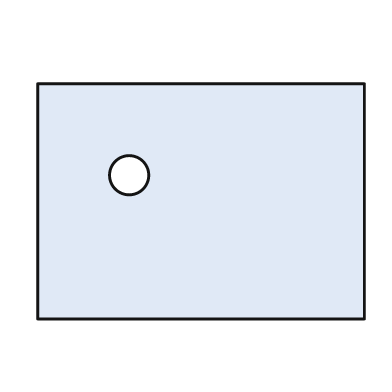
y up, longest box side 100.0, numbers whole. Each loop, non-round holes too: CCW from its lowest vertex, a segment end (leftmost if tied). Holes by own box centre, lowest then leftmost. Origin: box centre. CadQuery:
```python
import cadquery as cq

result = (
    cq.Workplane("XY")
    .moveTo(-50.0, -36.0)
    .lineTo(50.0, -36.0)
    .lineTo(50.0, 36.0)
    .lineTo(-50.0, 36.0)
    .close()
    .moveTo(-22.0, 8.0)
    .circle(6.0)
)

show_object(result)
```